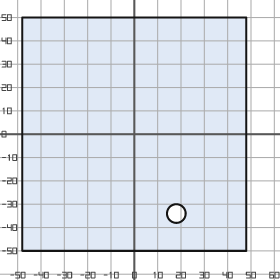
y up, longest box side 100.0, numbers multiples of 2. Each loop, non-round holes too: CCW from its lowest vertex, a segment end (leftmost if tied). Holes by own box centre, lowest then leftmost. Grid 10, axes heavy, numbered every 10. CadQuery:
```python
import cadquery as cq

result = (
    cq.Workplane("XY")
    .moveTo(-48.0, -50.0)
    .lineTo(48.0, -50.0)
    .lineTo(48.0, 50.0)
    .lineTo(-48.0, 50.0)
    .close()
    .moveTo(18.0, -34.0)
    .circle(4.0)
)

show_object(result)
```